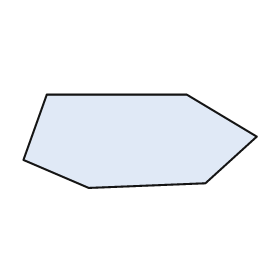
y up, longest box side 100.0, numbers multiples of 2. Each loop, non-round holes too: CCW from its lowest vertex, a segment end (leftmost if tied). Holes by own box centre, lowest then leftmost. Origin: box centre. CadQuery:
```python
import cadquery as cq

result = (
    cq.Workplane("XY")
    .moveTo(-22.0, -20.0)
    .lineTo(28.0, -18.0)
    .lineTo(50.0, 2.0)
    .lineTo(20.0, 20.0)
    .lineTo(-40.0, 20.0)
    .lineTo(-50.0, -8.0)
    .close()
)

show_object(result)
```